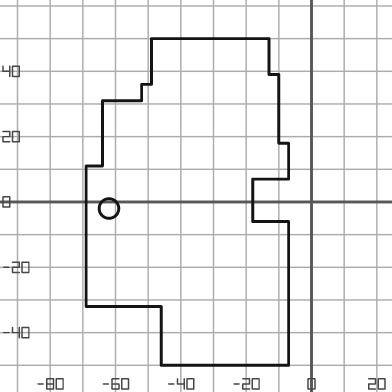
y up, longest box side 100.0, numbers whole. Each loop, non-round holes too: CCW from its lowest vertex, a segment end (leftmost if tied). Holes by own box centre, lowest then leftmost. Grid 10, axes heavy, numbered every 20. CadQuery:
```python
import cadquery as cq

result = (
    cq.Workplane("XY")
    .moveTo(-46.0, -50.0)
    .lineTo(-7.0, -50.0)
    .lineTo(-7.0, -6.0)
    .lineTo(-18.0, -6.0)
    .lineTo(-18.0, 7.0)
    .lineTo(-7.0, 7.0)
    .lineTo(-7.0, 18.0)
    .lineTo(-10.0, 18.0)
    .lineTo(-10.0, 39.0)
    .lineTo(-13.0, 39.0)
    .lineTo(-13.0, 50.0)
    .lineTo(-49.0, 50.0)
    .lineTo(-49.0, 36.0)
    .lineTo(-52.0, 36.0)
    .lineTo(-52.0, 31.0)
    .lineTo(-64.0, 31.0)
    .lineTo(-64.0, 11.0)
    .lineTo(-69.0, 11.0)
    .lineTo(-69.0, -32.0)
    .lineTo(-46.0, -32.0)
    .close()
    .moveTo(-62.0, -2.0)
    .circle(3.0)
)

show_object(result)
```